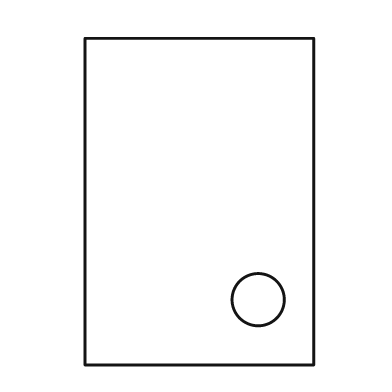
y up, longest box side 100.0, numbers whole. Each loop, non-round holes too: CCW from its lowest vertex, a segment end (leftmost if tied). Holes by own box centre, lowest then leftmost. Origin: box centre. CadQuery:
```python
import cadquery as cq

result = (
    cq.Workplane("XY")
    .moveTo(-35.0, -50.0)
    .lineTo(35.0, -50.0)
    .lineTo(35.0, 50.0)
    .lineTo(-35.0, 50.0)
    .close()
    .moveTo(18.0, -30.0)
    .circle(8.0)
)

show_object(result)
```